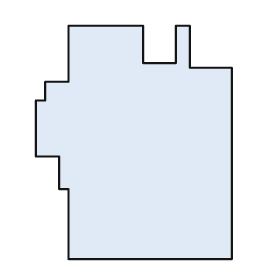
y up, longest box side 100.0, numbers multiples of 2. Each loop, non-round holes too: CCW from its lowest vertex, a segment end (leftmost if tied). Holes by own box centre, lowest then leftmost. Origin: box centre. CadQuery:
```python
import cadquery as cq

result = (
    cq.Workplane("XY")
    .moveTo(-28.0, -50.0)
    .lineTo(42.0, -50.0)
    .lineTo(42.0, 32.0)
    .lineTo(24.0, 32.0)
    .lineTo(24.0, 50.0)
    .lineTo(18.0, 50.0)
    .lineTo(18.0, 34.0)
    .lineTo(4.0, 34.0)
    .lineTo(4.0, 50.0)
    .lineTo(-28.0, 50.0)
    .lineTo(-28.0, 26.0)
    .lineTo(-38.0, 26.0)
    .lineTo(-38.0, 18.0)
    .lineTo(-42.0, 18.0)
    .lineTo(-42.0, -6.0)
    .lineTo(-32.0, -6.0)
    .lineTo(-32.0, -20.0)
    .lineTo(-28.0, -20.0)
    .close()
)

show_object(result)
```